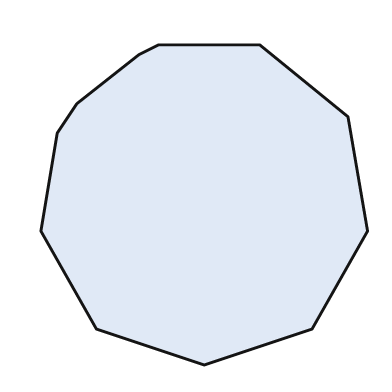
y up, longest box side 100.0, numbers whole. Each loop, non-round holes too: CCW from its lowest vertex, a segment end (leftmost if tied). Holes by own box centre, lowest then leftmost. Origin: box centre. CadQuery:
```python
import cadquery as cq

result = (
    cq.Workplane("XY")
    .moveTo(0.0, -49.0)
    .lineTo(33.0, -38.0)
    .lineTo(50.0, -8.0)
    .lineTo(44.0, 27.0)
    .lineTo(17.0, 49.0)
    .lineTo(-14.0, 49.0)
    .lineTo(-20.0, 46.0)
    .lineTo(-39.0, 31.0)
    .lineTo(-45.0, 22.0)
    .lineTo(-50.0, -8.0)
    .lineTo(-33.0, -38.0)
    .close()
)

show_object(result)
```